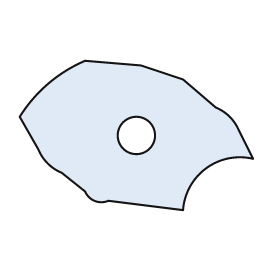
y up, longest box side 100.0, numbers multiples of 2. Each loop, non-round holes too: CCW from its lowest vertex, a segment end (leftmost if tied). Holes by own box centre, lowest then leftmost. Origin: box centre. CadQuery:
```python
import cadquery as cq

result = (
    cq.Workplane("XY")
    .moveTo(20.0, -32.0)
    .threePointArc((30.0, -14.0), (50.0, -10.0))
    .lineTo(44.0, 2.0)
    .threePointArc((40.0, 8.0), (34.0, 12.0))
    .lineTo(20.0, 24.0)
    .lineTo(2.0, 30.0)
    .lineTo(-22.0, 32.0)
    .threePointArc((-38.0, 22.0), (-50.0, 8.0))
    .lineTo(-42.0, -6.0)
    .threePointArc((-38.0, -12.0), (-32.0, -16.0))
    .lineTo(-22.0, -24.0)
    .threePointArc((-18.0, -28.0), (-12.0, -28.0))
    .close()
    .moveTo(0.0, 0.0)
    .circle(8.0)
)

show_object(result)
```